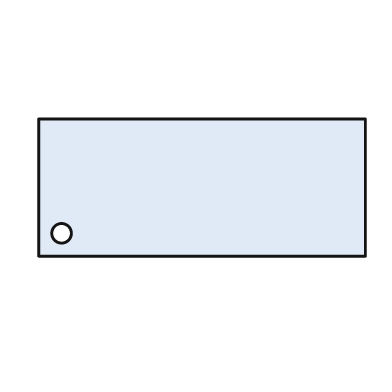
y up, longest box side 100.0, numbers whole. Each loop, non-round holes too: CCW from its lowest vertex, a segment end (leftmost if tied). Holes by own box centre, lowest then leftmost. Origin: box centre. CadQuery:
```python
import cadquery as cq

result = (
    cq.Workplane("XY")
    .moveTo(-50.0, -21.0)
    .lineTo(50.0, -21.0)
    .lineTo(50.0, 21.0)
    .lineTo(-50.0, 21.0)
    .close()
    .moveTo(-43.0, -14.0)
    .circle(3.0)
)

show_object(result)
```